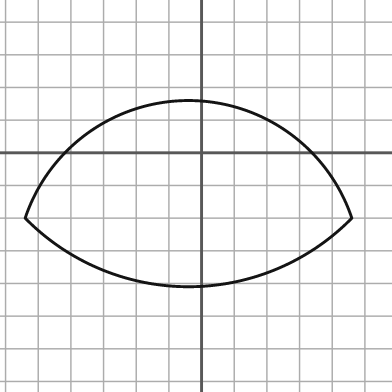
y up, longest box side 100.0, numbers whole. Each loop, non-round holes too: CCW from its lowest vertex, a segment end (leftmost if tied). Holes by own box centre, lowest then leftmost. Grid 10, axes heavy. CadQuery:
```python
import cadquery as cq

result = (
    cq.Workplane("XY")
    .moveTo(-54.0, -20.0)
    .threePointArc((-4.0, -41.0), (46.0, -20.0))
    .threePointArc((-4.0, 16.0), (-54.0, -20.0))
    .close()
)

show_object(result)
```